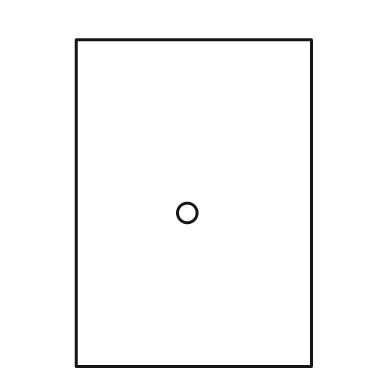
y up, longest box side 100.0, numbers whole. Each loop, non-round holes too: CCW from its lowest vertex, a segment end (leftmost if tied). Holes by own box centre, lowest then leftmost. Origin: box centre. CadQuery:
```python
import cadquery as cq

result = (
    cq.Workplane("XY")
    .moveTo(-36.0, -50.0)
    .lineTo(36.0, -50.0)
    .lineTo(36.0, 50.0)
    .lineTo(-36.0, 50.0)
    .close()
    .moveTo(-2.0, -3.0)
    .circle(3.0)
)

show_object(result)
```